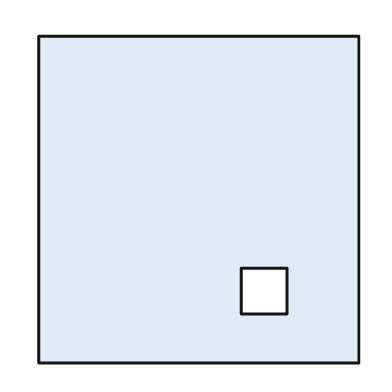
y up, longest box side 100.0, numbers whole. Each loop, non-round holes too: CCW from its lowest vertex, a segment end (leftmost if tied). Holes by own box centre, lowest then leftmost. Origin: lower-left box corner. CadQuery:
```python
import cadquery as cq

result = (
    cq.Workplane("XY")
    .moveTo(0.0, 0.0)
    .lineTo(98.0, 0.0)
    .lineTo(98.0, 100.0)
    .lineTo(0.0, 100.0)
    .close()
    .moveTo(62.0, 15.0)
    .lineTo(76.0, 15.0)
    .lineTo(76.0, 29.0)
    .lineTo(62.0, 29.0)
    .close()
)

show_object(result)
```